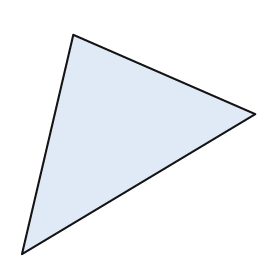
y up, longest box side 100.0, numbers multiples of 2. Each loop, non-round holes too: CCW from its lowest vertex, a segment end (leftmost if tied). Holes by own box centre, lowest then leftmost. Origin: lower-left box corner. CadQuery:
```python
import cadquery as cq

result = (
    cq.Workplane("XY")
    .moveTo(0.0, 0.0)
    .lineTo(100.0, 60.0)
    .lineTo(22.0, 94.0)
    .close()
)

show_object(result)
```